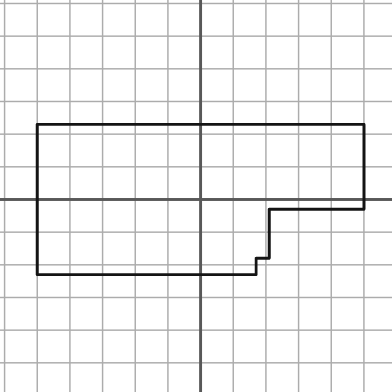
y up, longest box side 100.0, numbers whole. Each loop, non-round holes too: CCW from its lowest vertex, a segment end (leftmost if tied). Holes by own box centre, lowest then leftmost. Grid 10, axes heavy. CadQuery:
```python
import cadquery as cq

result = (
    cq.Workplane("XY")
    .moveTo(-50.0, -23.0)
    .lineTo(17.0, -23.0)
    .lineTo(17.0, -18.0)
    .lineTo(21.0, -18.0)
    .lineTo(21.0, -3.0)
    .lineTo(50.0, -3.0)
    .lineTo(50.0, 23.0)
    .lineTo(-50.0, 23.0)
    .close()
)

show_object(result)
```